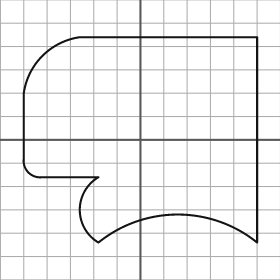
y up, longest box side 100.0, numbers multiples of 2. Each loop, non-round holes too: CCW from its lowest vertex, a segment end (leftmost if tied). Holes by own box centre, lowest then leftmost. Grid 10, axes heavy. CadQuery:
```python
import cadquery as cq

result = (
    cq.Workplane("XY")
    .moveTo(-18.0, -44.0)
    .threePointArc((16.0, -32.0), (50.0, -44.0))
    .lineTo(50.0, 44.0)
    .lineTo(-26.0, 44.0)
    .threePointArc((-42.0, 36.0), (-50.0, 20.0))
    .lineTo(-50.0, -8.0)
    .threePointArc((-48.0, -14.0), (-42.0, -16.0))
    .lineTo(-18.0, -16.0)
    .threePointArc((-26.0, -30.0), (-18.0, -44.0))
    .close()
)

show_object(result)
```